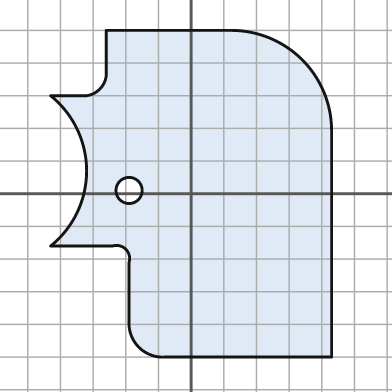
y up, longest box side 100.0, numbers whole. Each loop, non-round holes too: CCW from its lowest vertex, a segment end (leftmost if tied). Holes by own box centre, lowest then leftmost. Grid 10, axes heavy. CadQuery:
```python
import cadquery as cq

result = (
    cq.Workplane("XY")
    .moveTo(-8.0, -50.0)
    .lineTo(43.0, -50.0)
    .lineTo(43.0, 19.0)
    .threePointArc((34.0, 41.0), (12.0, 50.0))
    .lineTo(-26.0, 50.0)
    .lineTo(-26.0, 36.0)
    .threePointArc((-28.0, 32.0), (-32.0, 30.0))
    .lineTo(-43.0, 30.0)
    .threePointArc((-32.0, 7.0), (-43.0, -16.0))
    .lineTo(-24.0, -16.0)
    .threePointArc((-20.0, -17.0), (-19.0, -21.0))
    .lineTo(-19.0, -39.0)
    .threePointArc((-16.0, -47.0), (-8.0, -50.0))
    .close()
    .moveTo(-19.0, 1.0)
    .circle(4.0)
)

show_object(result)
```